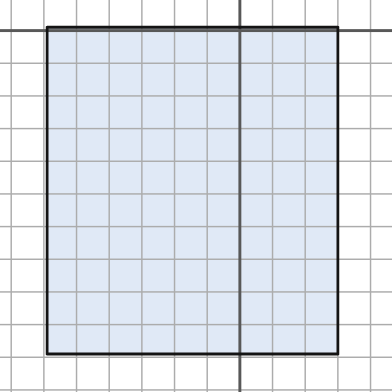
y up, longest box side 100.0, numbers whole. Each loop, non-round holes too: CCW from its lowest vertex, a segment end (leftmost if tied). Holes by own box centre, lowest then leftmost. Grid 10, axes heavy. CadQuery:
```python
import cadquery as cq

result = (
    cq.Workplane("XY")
    .moveTo(-59.0, -99.0)
    .lineTo(30.0, -99.0)
    .lineTo(30.0, 1.0)
    .lineTo(-59.0, 1.0)
    .close()
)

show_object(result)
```